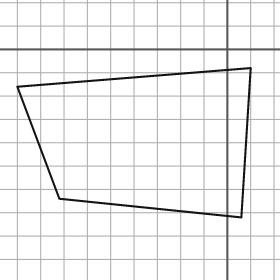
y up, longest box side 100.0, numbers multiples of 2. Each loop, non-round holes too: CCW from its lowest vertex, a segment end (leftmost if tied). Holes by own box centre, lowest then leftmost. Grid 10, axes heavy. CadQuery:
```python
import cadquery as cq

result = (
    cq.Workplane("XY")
    .moveTo(6.0, -72.0)
    .lineTo(10.0, -8.0)
    .lineTo(-90.0, -16.0)
    .lineTo(-72.0, -64.0)
    .close()
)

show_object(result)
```